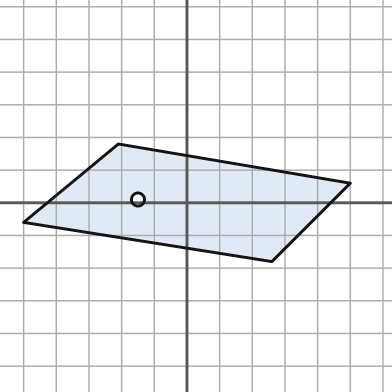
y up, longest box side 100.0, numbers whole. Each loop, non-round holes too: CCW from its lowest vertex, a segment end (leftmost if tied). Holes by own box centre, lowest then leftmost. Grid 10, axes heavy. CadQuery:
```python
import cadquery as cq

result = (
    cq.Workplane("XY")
    .moveTo(26.0, -18.0)
    .lineTo(50.0, 6.0)
    .lineTo(-21.0, 18.0)
    .lineTo(-50.0, -6.0)
    .close()
    .moveTo(-15.0, 1.0)
    .circle(2.0)
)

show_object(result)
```